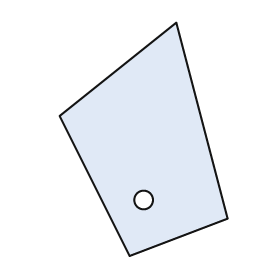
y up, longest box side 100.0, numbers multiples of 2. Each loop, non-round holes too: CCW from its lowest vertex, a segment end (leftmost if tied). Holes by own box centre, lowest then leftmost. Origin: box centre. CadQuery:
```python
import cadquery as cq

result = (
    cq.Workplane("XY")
    .moveTo(-6.0, -50.0)
    .lineTo(36.0, -34.0)
    .lineTo(14.0, 50.0)
    .lineTo(-36.0, 10.0)
    .close()
    .moveTo(0.0, -26.0)
    .circle(4.0)
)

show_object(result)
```